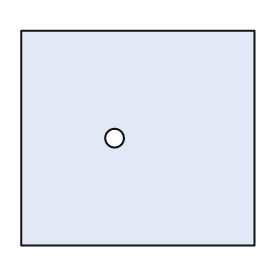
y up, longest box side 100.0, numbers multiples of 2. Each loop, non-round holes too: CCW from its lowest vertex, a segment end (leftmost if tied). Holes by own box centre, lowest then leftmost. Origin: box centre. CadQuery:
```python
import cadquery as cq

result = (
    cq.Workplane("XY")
    .moveTo(-50.0, -46.0)
    .lineTo(50.0, -46.0)
    .lineTo(50.0, 46.0)
    .lineTo(-50.0, 46.0)
    .close()
    .moveTo(-10.0, 0.0)
    .circle(4.0)
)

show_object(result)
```